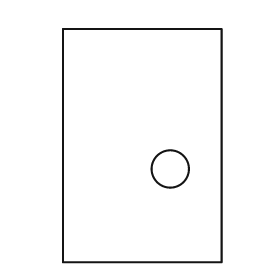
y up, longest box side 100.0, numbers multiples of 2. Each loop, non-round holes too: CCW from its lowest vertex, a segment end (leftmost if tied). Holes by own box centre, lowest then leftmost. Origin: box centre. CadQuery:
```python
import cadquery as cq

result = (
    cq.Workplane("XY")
    .moveTo(-34.0, -50.0)
    .lineTo(34.0, -50.0)
    .lineTo(34.0, 50.0)
    .lineTo(-34.0, 50.0)
    .close()
    .moveTo(12.0, -10.0)
    .circle(8.0)
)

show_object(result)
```